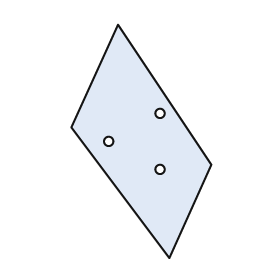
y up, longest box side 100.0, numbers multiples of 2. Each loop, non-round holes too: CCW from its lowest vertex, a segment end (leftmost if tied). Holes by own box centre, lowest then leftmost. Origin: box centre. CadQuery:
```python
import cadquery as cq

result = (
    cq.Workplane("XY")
    .moveTo(12.0, -50.0)
    .lineTo(30.0, -10.0)
    .lineTo(-10.0, 50.0)
    .lineTo(-30.0, 6.0)
    .close()
    .moveTo(8.0, -12.0)
    .circle(2.0)
    .moveTo(-14.0, 0.0)
    .circle(2.0)
    .moveTo(8.0, 12.0)
    .circle(2.0)
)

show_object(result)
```